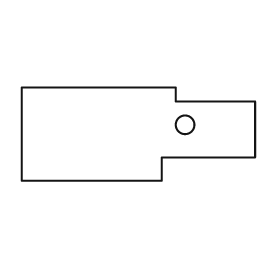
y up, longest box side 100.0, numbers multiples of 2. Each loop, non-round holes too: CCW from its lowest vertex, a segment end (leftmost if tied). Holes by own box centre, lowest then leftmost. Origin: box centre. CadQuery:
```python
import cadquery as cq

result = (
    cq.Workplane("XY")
    .moveTo(-50.0, -20.0)
    .lineTo(10.0, -20.0)
    .lineTo(10.0, -10.0)
    .lineTo(50.0, -10.0)
    .lineTo(50.0, 14.0)
    .lineTo(16.0, 14.0)
    .lineTo(16.0, 20.0)
    .lineTo(-50.0, 20.0)
    .close()
    .moveTo(20.0, 4.0)
    .circle(4.0)
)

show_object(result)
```